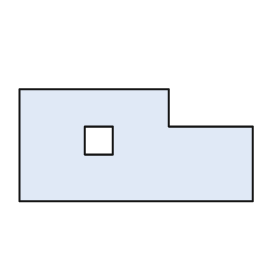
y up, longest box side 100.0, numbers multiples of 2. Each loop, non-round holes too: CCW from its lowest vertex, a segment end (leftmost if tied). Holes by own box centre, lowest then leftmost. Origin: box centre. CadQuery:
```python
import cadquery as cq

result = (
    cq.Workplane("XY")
    .moveTo(-50.0, -24.0)
    .lineTo(50.0, -24.0)
    .lineTo(50.0, 8.0)
    .lineTo(14.0, 8.0)
    .lineTo(14.0, 24.0)
    .lineTo(-50.0, 24.0)
    .close()
    .moveTo(-22.0, -4.0)
    .lineTo(-10.0, -4.0)
    .lineTo(-10.0, 8.0)
    .lineTo(-22.0, 8.0)
    .close()
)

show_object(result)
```